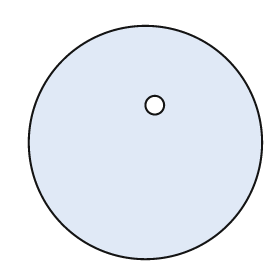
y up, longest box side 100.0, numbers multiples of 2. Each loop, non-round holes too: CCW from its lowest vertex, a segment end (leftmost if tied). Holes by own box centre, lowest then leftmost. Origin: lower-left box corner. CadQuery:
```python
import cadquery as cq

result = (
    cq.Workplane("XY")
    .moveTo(50.0, 50.0)
    .circle(50.0)
    .moveTo(54.0, 66.0)
    .circle(4.0)
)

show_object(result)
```